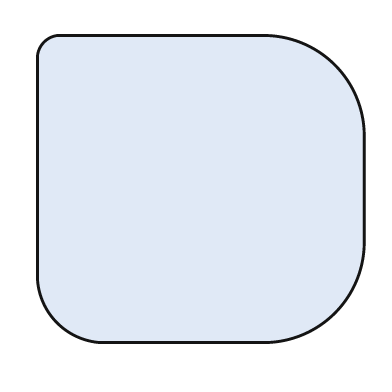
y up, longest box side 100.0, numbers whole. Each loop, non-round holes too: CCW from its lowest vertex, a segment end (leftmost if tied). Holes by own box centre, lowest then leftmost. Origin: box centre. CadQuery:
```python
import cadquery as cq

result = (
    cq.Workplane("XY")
    .moveTo(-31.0, -47.0)
    .lineTo(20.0, -47.0)
    .threePointArc((41.0, -38.0), (50.0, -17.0))
    .lineTo(50.0, 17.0)
    .threePointArc((41.0, 38.0), (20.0, 47.0))
    .lineTo(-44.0, 47.0)
    .threePointArc((-48.0, 45.0), (-50.0, 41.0))
    .lineTo(-50.0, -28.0)
    .threePointArc((-44.0, -41.0), (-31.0, -47.0))
    .close()
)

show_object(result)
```